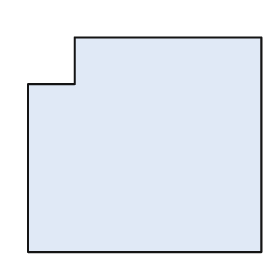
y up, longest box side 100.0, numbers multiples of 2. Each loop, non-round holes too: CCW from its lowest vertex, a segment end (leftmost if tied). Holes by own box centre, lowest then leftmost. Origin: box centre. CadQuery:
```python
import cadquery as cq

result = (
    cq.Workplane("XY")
    .moveTo(-50.0, -46.0)
    .lineTo(50.0, -46.0)
    .lineTo(50.0, 46.0)
    .lineTo(-30.0, 46.0)
    .lineTo(-30.0, 26.0)
    .lineTo(-50.0, 26.0)
    .close()
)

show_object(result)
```